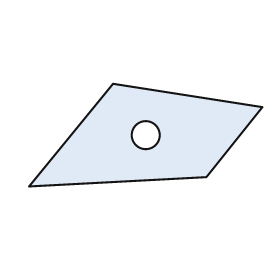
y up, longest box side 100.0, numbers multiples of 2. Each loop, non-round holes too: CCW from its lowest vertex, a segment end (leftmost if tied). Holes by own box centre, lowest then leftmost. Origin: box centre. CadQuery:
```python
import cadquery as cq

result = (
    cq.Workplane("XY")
    .moveTo(-50.0, -22.0)
    .lineTo(26.0, -18.0)
    .lineTo(50.0, 12.0)
    .lineTo(-14.0, 22.0)
    .close()
    .moveTo(0.0, 0.0)
    .circle(6.0)
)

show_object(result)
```